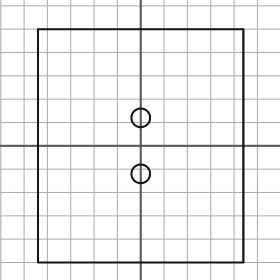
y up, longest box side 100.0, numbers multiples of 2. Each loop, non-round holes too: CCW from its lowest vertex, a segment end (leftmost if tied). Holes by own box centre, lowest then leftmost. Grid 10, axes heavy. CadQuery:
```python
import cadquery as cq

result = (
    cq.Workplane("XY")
    .moveTo(-44.0, -50.0)
    .lineTo(44.0, -50.0)
    .lineTo(44.0, 50.0)
    .lineTo(-44.0, 50.0)
    .close()
    .moveTo(0.0, -12.0)
    .circle(4.0)
    .moveTo(0.0, 12.0)
    .circle(4.0)
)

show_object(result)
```